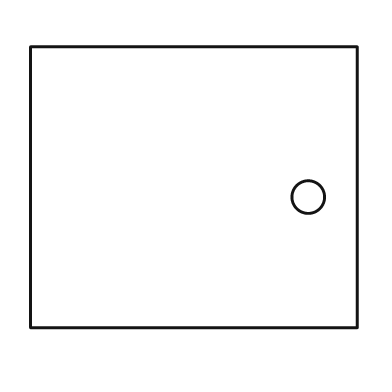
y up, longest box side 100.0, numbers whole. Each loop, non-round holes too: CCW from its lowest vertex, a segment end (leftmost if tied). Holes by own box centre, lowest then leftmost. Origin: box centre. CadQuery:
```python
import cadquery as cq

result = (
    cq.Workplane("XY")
    .moveTo(-50.0, -43.0)
    .lineTo(50.0, -43.0)
    .lineTo(50.0, 43.0)
    .lineTo(-50.0, 43.0)
    .close()
    .moveTo(35.0, -3.0)
    .circle(5.0)
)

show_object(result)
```